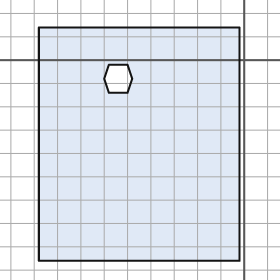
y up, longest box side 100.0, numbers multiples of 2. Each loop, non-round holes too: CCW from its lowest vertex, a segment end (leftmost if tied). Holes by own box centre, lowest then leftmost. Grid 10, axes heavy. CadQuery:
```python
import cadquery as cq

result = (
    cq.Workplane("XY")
    .moveTo(-88.0, -86.0)
    .lineTo(-2.0, -86.0)
    .lineTo(-2.0, 14.0)
    .lineTo(-88.0, 14.0)
    .close()
    .moveTo(-58.0, -14.0)
    .lineTo(-50.0, -14.0)
    .lineTo(-48.0, -8.0)
    .lineTo(-50.0, -2.0)
    .lineTo(-58.0, -2.0)
    .lineTo(-60.0, -8.0)
    .close()
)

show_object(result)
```